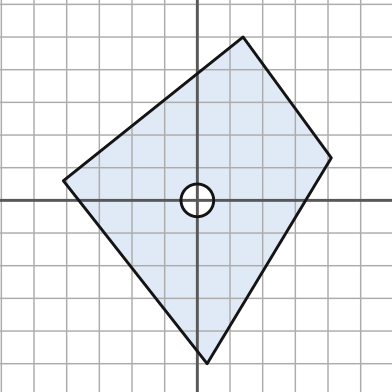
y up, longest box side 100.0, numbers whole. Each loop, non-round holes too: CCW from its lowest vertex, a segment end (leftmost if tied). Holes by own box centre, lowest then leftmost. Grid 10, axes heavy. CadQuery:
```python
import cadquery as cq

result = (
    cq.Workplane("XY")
    .moveTo(3.0, -50.0)
    .lineTo(41.0, 13.0)
    .lineTo(14.0, 50.0)
    .lineTo(-41.0, 6.0)
    .close()
    .moveTo(0.0, 0.0)
    .circle(5.0)
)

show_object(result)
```